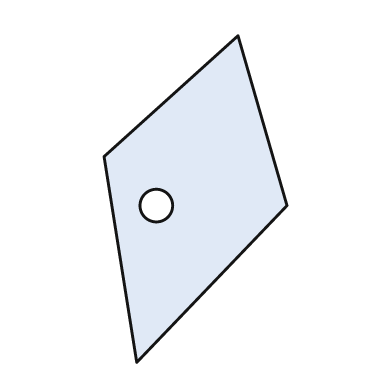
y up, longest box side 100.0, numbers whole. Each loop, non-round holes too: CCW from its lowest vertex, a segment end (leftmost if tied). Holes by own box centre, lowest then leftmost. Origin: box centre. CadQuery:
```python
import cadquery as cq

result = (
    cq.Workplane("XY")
    .moveTo(-18.0, -50.0)
    .lineTo(28.0, -2.0)
    .lineTo(13.0, 50.0)
    .lineTo(-28.0, 13.0)
    .close()
    .moveTo(-12.0, -2.0)
    .circle(5.0)
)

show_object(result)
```